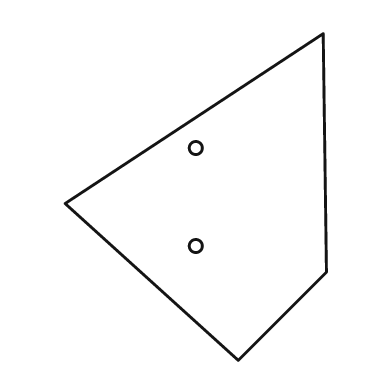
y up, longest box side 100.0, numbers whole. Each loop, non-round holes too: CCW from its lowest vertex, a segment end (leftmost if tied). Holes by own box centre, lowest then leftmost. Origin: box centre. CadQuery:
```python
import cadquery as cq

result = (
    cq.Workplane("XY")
    .moveTo(13.0, -50.0)
    .lineTo(40.0, -23.0)
    .lineTo(39.0, 50.0)
    .lineTo(-40.0, -2.0)
    .close()
    .moveTo(0.0, -15.0)
    .circle(2.0)
    .moveTo(0.0, 15.0)
    .circle(2.0)
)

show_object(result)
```